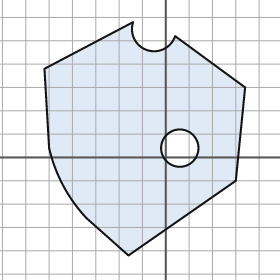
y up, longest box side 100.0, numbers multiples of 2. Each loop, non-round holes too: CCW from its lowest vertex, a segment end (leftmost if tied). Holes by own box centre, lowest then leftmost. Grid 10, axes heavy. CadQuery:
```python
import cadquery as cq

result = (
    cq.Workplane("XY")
    .moveTo(-16.0, -42.0)
    .lineTo(30.0, -10.0)
    .lineTo(34.0, 30.0)
    .lineTo(4.0, 52.0)
    .threePointArc((-8.0, 46.0), (-14.0, 58.0))
    .lineTo(-52.0, 38.0)
    .lineTo(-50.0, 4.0)
    .threePointArc((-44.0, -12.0), (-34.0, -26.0))
    .close()
    .moveTo(6.0, 4.0)
    .circle(8.0)
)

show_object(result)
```